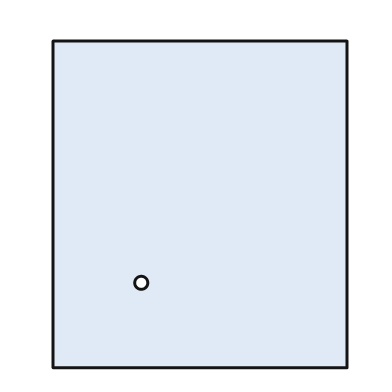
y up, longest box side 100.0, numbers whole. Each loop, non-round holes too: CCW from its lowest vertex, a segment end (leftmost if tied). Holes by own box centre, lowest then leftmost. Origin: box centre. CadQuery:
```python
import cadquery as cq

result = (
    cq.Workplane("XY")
    .moveTo(-45.0, -50.0)
    .lineTo(45.0, -50.0)
    .lineTo(45.0, 50.0)
    .lineTo(-45.0, 50.0)
    .close()
    .moveTo(-18.0, -24.0)
    .circle(2.0)
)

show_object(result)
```